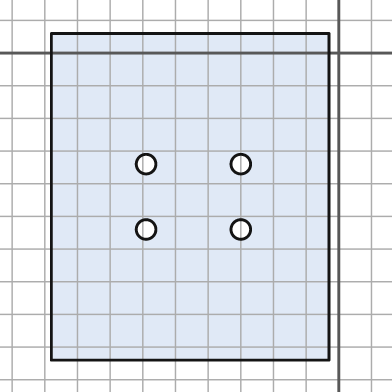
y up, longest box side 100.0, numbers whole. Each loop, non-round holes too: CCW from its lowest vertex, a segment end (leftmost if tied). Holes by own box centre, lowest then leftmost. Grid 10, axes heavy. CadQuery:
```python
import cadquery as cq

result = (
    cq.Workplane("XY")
    .moveTo(-88.0, -94.0)
    .lineTo(-3.0, -94.0)
    .lineTo(-3.0, 6.0)
    .lineTo(-88.0, 6.0)
    .close()
    .moveTo(-59.0, -54.0)
    .circle(3.0)
    .moveTo(-30.0, -54.0)
    .circle(3.0)
    .moveTo(-59.0, -34.0)
    .circle(3.0)
    .moveTo(-30.0, -34.0)
    .circle(3.0)
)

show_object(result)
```